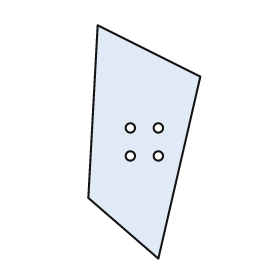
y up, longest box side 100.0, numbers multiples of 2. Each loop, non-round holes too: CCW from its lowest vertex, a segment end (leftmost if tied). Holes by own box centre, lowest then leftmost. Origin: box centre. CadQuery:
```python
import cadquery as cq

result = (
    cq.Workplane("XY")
    .moveTo(6.0, -50.0)
    .lineTo(24.0, 28.0)
    .lineTo(-20.0, 50.0)
    .lineTo(-24.0, -24.0)
    .close()
    .moveTo(-6.0, -6.0)
    .circle(2.0)
    .moveTo(6.0, -6.0)
    .circle(2.0)
    .moveTo(-6.0, 6.0)
    .circle(2.0)
    .moveTo(6.0, 6.0)
    .circle(2.0)
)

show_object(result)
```